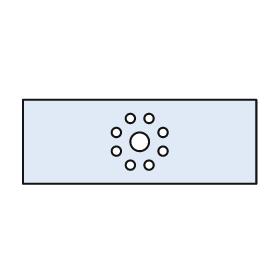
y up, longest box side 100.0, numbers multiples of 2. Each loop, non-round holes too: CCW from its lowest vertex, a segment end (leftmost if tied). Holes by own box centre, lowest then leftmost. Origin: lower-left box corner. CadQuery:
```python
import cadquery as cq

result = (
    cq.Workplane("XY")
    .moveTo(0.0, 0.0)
    .lineTo(100.0, 0.0)
    .lineTo(100.0, 36.0)
    .lineTo(0.0, 36.0)
    .close()
    .moveTo(46.0, 8.0)
    .circle(2.0)
    .moveTo(54.0, 8.0)
    .circle(2.0)
    .moveTo(40.0, 14.0)
    .circle(2.0)
    .moveTo(60.0, 14.0)
    .circle(2.0)
    .moveTo(50.0, 18.0)
    .circle(4.0)
    .moveTo(40.0, 22.0)
    .circle(2.0)
    .moveTo(60.0, 22.0)
    .circle(2.0)
    .moveTo(46.0, 28.0)
    .circle(2.0)
    .moveTo(54.0, 28.0)
    .circle(2.0)
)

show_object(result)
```